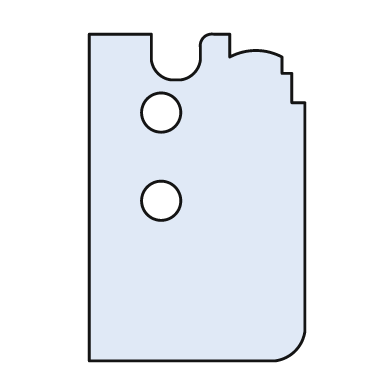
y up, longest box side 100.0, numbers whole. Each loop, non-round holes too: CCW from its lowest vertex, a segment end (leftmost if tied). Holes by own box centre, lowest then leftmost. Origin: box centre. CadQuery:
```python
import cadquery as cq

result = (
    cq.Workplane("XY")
    .moveTo(-33.0, -50.0)
    .lineTo(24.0, -50.0)
    .threePointArc((30.0, -47.0), (33.0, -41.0))
    .lineTo(33.0, 29.0)
    .lineTo(29.0, 29.0)
    .lineTo(29.0, 38.0)
    .lineTo(26.0, 38.0)
    .lineTo(26.0, 43.0)
    .threePointArc((18.0, 45.0), (10.0, 43.0))
    .lineTo(10.0, 50.0)
    .lineTo(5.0, 50.0)
    .threePointArc((2.0, 49.0), (1.0, 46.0))
    .lineTo(1.0, 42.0)
    .threePointArc((-1.0, 38.0), (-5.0, 36.0))
    .lineTo(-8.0, 36.0)
    .threePointArc((-12.0, 38.0), (-14.0, 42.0))
    .lineTo(-14.0, 50.0)
    .lineTo(-33.0, 50.0)
    .close()
    .moveTo(-11.0, -1.0)
    .circle(6.0)
    .moveTo(-11.0, 26.0)
    .circle(6.0)
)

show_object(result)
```